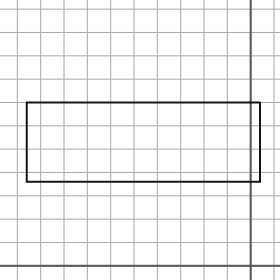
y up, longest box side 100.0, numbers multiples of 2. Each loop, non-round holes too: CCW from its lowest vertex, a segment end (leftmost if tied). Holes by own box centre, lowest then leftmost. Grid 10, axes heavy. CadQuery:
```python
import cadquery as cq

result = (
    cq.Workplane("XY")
    .moveTo(-96.0, 36.0)
    .lineTo(4.0, 36.0)
    .lineTo(4.0, 70.0)
    .lineTo(-96.0, 70.0)
    .close()
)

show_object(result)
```